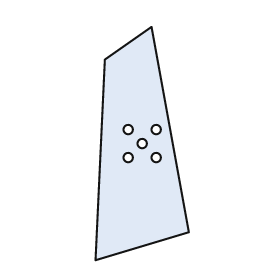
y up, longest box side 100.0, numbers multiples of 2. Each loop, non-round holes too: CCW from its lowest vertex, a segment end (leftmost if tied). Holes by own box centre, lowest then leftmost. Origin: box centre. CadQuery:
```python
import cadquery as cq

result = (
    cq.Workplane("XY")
    .moveTo(-20.0, -50.0)
    .lineTo(20.0, -38.0)
    .lineTo(4.0, 50.0)
    .lineTo(-16.0, 36.0)
    .close()
    .moveTo(-6.0, -6.0)
    .circle(2.0)
    .moveTo(6.0, -6.0)
    .circle(2.0)
    .moveTo(0.0, 0.0)
    .circle(2.0)
    .moveTo(-6.0, 6.0)
    .circle(2.0)
    .moveTo(6.0, 6.0)
    .circle(2.0)
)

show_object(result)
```